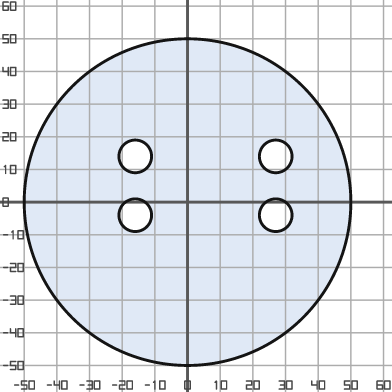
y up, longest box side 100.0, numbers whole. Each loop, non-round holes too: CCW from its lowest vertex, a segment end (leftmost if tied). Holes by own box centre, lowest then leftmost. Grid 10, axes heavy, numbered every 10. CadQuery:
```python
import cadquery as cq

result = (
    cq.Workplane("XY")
    .moveTo(0.0, 0.0)
    .circle(50.0)
    .moveTo(-16.0, -4.0)
    .circle(5.0)
    .moveTo(27.0, -4.0)
    .circle(5.0)
    .moveTo(-16.0, 14.0)
    .circle(5.0)
    .moveTo(27.0, 14.0)
    .circle(5.0)
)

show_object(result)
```